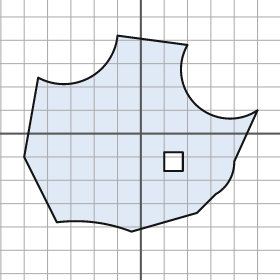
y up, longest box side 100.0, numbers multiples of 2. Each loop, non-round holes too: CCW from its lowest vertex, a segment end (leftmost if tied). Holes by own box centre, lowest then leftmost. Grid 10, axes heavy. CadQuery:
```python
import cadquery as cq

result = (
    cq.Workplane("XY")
    .moveTo(-4.0, -42.0)
    .lineTo(24.0, -34.0)
    .lineTo(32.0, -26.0)
    .threePointArc((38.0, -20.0), (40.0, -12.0))
    .lineTo(50.0, 10.0)
    .threePointArc((24.0, 12.0), (20.0, 38.0))
    .lineTo(-10.0, 42.0)
    .threePointArc((-22.0, 24.0), (-44.0, 24.0))
    .lineTo(-50.0, -10.0)
    .lineTo(-36.0, -38.0)
    .threePointArc((-20.0, -38.0), (-4.0, -42.0))
    .close()
    .moveTo(10.0, -16.0)
    .lineTo(18.0, -16.0)
    .lineTo(18.0, -8.0)
    .lineTo(10.0, -8.0)
    .close()
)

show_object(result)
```